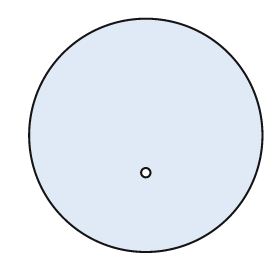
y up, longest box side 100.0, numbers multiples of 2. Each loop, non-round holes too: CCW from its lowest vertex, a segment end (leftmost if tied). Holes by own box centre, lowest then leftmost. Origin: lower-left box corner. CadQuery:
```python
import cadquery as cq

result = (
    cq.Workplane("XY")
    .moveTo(50.0, 50.0)
    .circle(50.0)
    .moveTo(50.0, 34.0)
    .circle(2.0)
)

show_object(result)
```